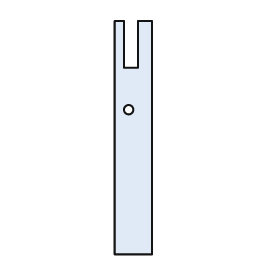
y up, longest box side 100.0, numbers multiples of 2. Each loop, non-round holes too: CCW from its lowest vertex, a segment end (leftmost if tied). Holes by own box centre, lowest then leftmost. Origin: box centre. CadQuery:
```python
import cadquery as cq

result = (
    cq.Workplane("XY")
    .moveTo(-8.0, -50.0)
    .lineTo(8.0, -50.0)
    .lineTo(8.0, 50.0)
    .lineTo(2.0, 50.0)
    .lineTo(2.0, 30.0)
    .lineTo(-4.0, 30.0)
    .lineTo(-4.0, 50.0)
    .lineTo(-8.0, 50.0)
    .close()
    .moveTo(-2.0, 12.0)
    .circle(2.0)
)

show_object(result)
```